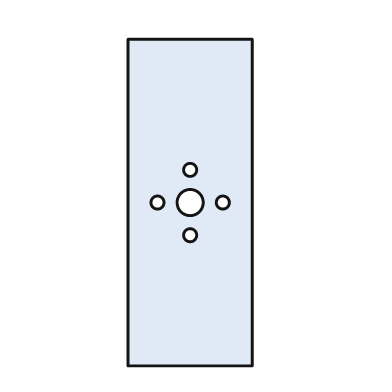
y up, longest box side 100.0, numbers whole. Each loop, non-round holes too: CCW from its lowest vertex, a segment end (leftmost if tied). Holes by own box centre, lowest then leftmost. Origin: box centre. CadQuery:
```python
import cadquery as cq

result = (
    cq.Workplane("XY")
    .moveTo(-19.0, -50.0)
    .lineTo(19.0, -50.0)
    .lineTo(19.0, 50.0)
    .lineTo(-19.0, 50.0)
    .close()
    .moveTo(0.0, -10.0)
    .circle(2.0)
    .moveTo(-10.0, 0.0)
    .circle(2.0)
    .moveTo(0.0, 0.0)
    .circle(4.0)
    .moveTo(10.0, 0.0)
    .circle(2.0)
    .moveTo(0.0, 10.0)
    .circle(2.0)
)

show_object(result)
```